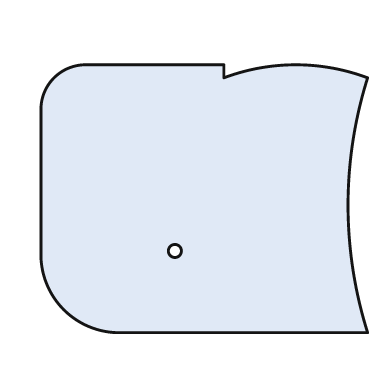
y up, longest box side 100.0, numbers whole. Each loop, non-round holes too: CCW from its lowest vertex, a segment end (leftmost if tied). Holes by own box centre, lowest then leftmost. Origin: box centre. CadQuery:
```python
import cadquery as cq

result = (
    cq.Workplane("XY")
    .moveTo(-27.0, -41.0)
    .lineTo(50.0, -41.0)
    .threePointArc((44.0, -2.0), (50.0, 37.0))
    .threePointArc((28.0, 41.0), (6.0, 37.0))
    .lineTo(6.0, 41.0)
    .lineTo(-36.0, 41.0)
    .threePointArc((-46.0, 37.0), (-50.0, 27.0))
    .lineTo(-50.0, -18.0)
    .threePointArc((-43.0, -34.0), (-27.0, -41.0))
    .close()
    .moveTo(-9.0, -16.0)
    .circle(2.0)
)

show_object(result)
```